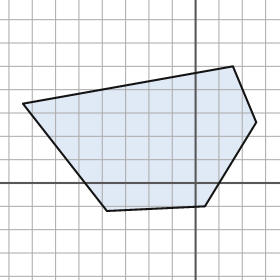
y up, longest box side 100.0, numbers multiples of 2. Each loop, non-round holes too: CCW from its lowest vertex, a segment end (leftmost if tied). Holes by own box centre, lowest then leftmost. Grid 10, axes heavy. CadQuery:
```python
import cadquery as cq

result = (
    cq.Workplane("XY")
    .moveTo(-38.0, -12.0)
    .lineTo(4.0, -10.0)
    .lineTo(26.0, 26.0)
    .lineTo(16.0, 50.0)
    .lineTo(-74.0, 34.0)
    .close()
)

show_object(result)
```